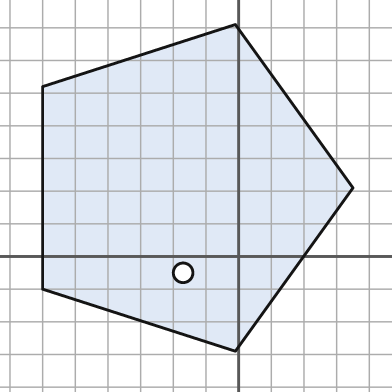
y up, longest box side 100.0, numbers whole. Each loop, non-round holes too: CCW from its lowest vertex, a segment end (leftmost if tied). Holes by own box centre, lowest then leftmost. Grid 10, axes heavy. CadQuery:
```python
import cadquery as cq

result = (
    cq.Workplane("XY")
    .moveTo(-1.0, -29.0)
    .lineTo(35.0, 21.0)
    .lineTo(-1.0, 71.0)
    .lineTo(-60.0, 52.0)
    .lineTo(-60.0, -10.0)
    .close()
    .moveTo(-17.0, -5.0)
    .circle(3.0)
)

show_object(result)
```